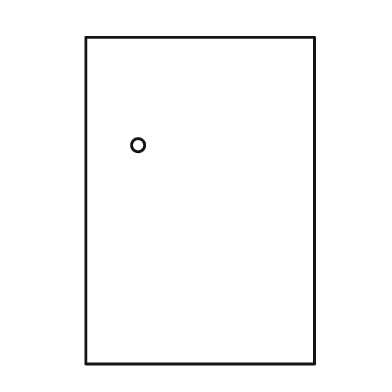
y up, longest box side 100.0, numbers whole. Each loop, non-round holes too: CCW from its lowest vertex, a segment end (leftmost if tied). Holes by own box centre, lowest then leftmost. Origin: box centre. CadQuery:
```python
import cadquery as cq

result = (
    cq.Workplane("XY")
    .moveTo(-35.0, -50.0)
    .lineTo(35.0, -50.0)
    .lineTo(35.0, 50.0)
    .lineTo(-35.0, 50.0)
    .close()
    .moveTo(-19.0, 17.0)
    .circle(2.0)
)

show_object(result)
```